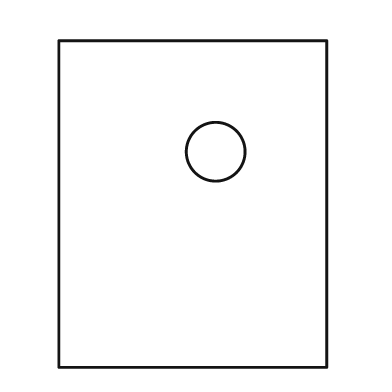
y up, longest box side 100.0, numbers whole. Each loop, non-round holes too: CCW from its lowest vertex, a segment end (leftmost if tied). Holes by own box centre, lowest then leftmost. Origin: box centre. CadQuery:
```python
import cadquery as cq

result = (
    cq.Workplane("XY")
    .moveTo(-41.0, -50.0)
    .lineTo(41.0, -50.0)
    .lineTo(41.0, 50.0)
    .lineTo(-41.0, 50.0)
    .close()
    .moveTo(7.0, 16.0)
    .circle(9.0)
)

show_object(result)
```